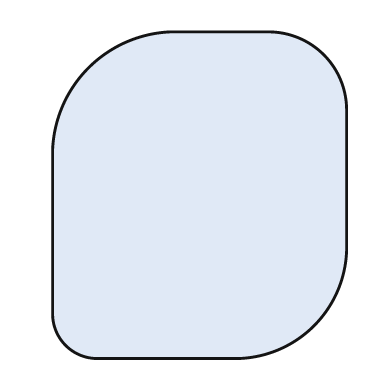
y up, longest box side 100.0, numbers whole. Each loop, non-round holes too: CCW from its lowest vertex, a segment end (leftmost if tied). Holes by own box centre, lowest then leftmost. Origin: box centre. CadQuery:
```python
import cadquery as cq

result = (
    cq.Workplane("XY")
    .moveTo(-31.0, -50.0)
    .lineTo(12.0, -50.0)
    .threePointArc((35.0, -40.0), (45.0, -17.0))
    .lineTo(45.0, 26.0)
    .threePointArc((38.0, 43.0), (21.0, 50.0))
    .lineTo(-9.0, 50.0)
    .threePointArc((-34.0, 39.0), (-45.0, 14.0))
    .lineTo(-45.0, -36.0)
    .threePointArc((-41.0, -46.0), (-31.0, -50.0))
    .close()
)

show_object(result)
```